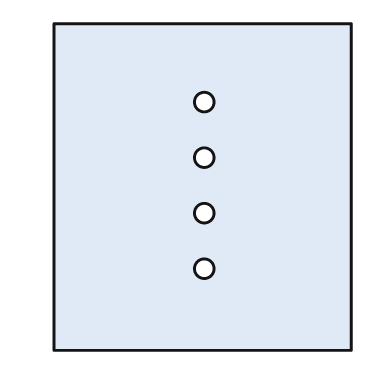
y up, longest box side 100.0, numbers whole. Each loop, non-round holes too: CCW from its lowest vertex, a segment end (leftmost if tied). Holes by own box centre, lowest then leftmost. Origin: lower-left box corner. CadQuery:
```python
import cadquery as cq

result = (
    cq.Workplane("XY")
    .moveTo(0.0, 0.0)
    .lineTo(91.0, 0.0)
    .lineTo(91.0, 100.0)
    .lineTo(0.0, 100.0)
    .close()
    .moveTo(46.0, 25.0)
    .circle(3.0)
    .moveTo(46.0, 42.0)
    .circle(3.0)
    .moveTo(46.0, 59.0)
    .circle(3.0)
    .moveTo(46.0, 76.0)
    .circle(3.0)
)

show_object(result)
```